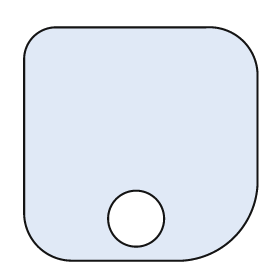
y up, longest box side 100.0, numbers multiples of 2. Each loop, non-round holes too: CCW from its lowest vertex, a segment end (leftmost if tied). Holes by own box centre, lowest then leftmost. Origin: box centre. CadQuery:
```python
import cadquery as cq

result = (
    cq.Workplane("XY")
    .moveTo(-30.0, -50.0)
    .lineTo(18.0, -50.0)
    .threePointArc((40.0, -40.0), (50.0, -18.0))
    .lineTo(50.0, 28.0)
    .threePointArc((44.0, 44.0), (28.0, 50.0))
    .lineTo(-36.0, 50.0)
    .threePointArc((-46.0, 46.0), (-50.0, 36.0))
    .lineTo(-50.0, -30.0)
    .threePointArc((-44.0, -44.0), (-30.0, -50.0))
    .close()
    .moveTo(-2.0, -32.0)
    .circle(12.0)
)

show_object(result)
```